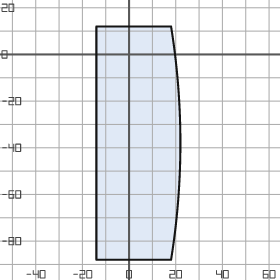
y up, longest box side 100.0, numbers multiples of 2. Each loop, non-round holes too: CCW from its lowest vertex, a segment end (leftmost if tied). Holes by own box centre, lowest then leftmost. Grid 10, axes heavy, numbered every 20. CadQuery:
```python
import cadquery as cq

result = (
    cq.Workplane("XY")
    .moveTo(-14.0, -88.0)
    .lineTo(18.0, -88.0)
    .threePointArc((22.0, -38.0), (18.0, 12.0))
    .lineTo(-14.0, 12.0)
    .close()
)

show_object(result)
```